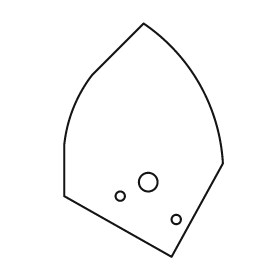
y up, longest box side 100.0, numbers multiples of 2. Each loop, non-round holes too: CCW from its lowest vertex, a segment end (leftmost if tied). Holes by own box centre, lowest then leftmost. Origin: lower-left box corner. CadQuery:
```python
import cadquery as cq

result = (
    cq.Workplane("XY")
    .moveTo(46.0, 0.0)
    .lineTo(68.0, 40.0)
    .threePointArc((58.0, 74.0), (34.0, 100.0))
    .lineTo(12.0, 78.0)
    .threePointArc((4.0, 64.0), (0.0, 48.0))
    .lineTo(0.0, 26.0)
    .close()
    .moveTo(48.0, 16.0)
    .circle(2.0)
    .moveTo(24.0, 26.0)
    .circle(2.0)
    .moveTo(36.0, 32.0)
    .circle(4.0)
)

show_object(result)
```